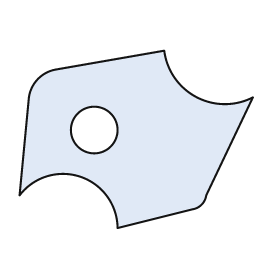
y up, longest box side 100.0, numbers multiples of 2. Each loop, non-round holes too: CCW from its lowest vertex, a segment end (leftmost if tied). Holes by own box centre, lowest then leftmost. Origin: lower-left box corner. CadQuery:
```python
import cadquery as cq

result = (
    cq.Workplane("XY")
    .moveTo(42.0, 0.0)
    .lineTo(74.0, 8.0)
    .threePointArc((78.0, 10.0), (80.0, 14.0))
    .lineTo(100.0, 56.0)
    .threePointArc((76.0, 56.0), (62.0, 76.0))
    .lineTo(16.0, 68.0)
    .threePointArc((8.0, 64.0), (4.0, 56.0))
    .lineTo(0.0, 14.0)
    .threePointArc((26.0, 22.0), (42.0, 0.0))
    .close()
    .moveTo(32.0, 42.0)
    .circle(10.0)
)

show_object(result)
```